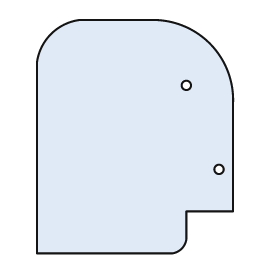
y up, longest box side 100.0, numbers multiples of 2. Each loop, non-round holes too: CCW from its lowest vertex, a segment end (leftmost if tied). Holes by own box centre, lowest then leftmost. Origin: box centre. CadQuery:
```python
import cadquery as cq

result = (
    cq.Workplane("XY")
    .moveTo(-42.0, -50.0)
    .lineTo(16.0, -50.0)
    .threePointArc((20.0, -48.0), (22.0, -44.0))
    .lineTo(22.0, -32.0)
    .lineTo(42.0, -32.0)
    .lineTo(42.0, 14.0)
    .threePointArc((32.0, 40.0), (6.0, 50.0))
    .lineTo(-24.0, 50.0)
    .threePointArc((-36.0, 44.0), (-42.0, 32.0))
    .close()
    .moveTo(36.0, -14.0)
    .circle(2.0)
    .moveTo(22.0, 22.0)
    .circle(2.0)
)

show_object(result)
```